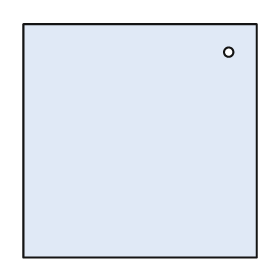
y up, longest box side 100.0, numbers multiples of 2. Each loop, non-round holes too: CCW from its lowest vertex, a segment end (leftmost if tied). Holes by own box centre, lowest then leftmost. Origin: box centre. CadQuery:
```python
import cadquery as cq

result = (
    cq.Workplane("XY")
    .moveTo(-50.0, -50.0)
    .lineTo(50.0, -50.0)
    .lineTo(50.0, 50.0)
    .lineTo(-50.0, 50.0)
    .close()
    .moveTo(38.0, 38.0)
    .circle(2.0)
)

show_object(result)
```